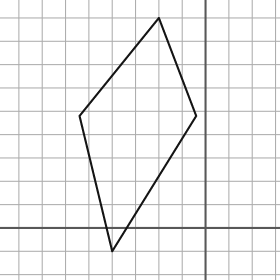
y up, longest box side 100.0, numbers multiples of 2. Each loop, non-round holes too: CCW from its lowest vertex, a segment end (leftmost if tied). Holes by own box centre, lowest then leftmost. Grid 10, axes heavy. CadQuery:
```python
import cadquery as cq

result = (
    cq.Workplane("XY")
    .moveTo(-40.0, -10.0)
    .lineTo(-4.0, 48.0)
    .lineTo(-20.0, 90.0)
    .lineTo(-54.0, 48.0)
    .close()
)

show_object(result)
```